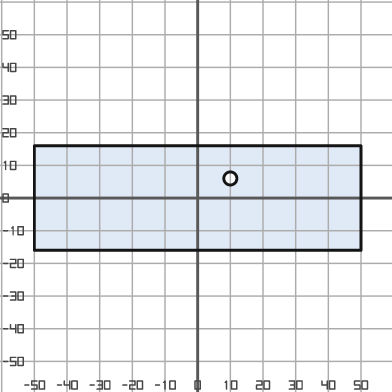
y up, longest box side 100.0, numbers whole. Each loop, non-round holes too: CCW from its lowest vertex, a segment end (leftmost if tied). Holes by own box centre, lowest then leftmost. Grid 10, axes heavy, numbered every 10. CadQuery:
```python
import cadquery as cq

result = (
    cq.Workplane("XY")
    .moveTo(-50.0, -16.0)
    .lineTo(50.0, -16.0)
    .lineTo(50.0, 16.0)
    .lineTo(-50.0, 16.0)
    .close()
    .moveTo(10.0, 6.0)
    .circle(2.0)
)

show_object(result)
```